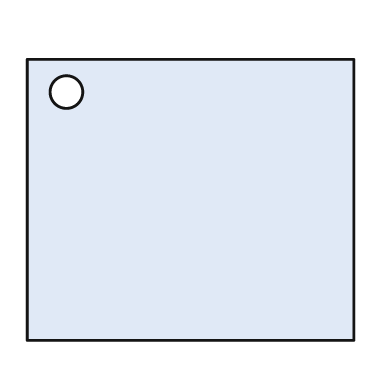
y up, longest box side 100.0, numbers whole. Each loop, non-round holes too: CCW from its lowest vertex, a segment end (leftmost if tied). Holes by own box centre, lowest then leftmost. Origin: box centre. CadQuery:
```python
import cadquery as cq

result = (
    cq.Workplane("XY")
    .moveTo(-50.0, -43.0)
    .lineTo(50.0, -43.0)
    .lineTo(50.0, 43.0)
    .lineTo(-50.0, 43.0)
    .close()
    .moveTo(-38.0, 33.0)
    .circle(5.0)
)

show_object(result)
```